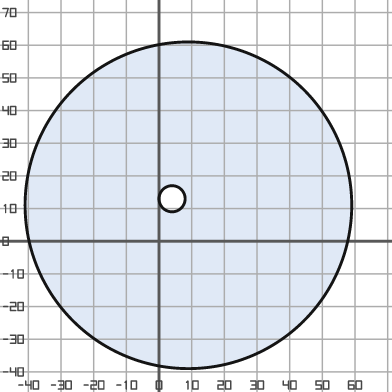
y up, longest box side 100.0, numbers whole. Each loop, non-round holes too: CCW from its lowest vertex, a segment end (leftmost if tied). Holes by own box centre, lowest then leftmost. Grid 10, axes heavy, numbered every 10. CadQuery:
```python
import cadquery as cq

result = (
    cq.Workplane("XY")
    .moveTo(9.0, 11.0)
    .circle(50.0)
    .moveTo(4.0, 13.0)
    .circle(4.0)
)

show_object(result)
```